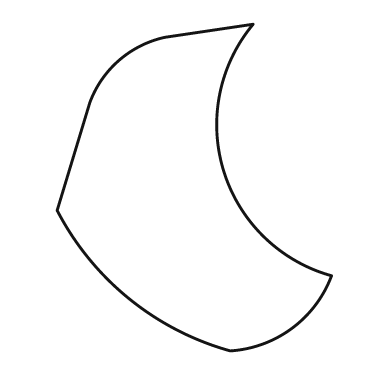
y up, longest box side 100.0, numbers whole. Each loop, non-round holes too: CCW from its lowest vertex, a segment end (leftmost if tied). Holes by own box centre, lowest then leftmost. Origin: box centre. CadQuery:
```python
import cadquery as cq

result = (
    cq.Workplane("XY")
    .moveTo(11.0, -50.0)
    .threePointArc((30.0, -43.0), (42.0, -27.0))
    .threePointArc((9.0, 5.0), (18.0, 50.0))
    .lineTo(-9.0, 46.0)
    .threePointArc((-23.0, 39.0), (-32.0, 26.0))
    .lineTo(-42.0, -7.0)
    .threePointArc((-20.0, -34.0), (11.0, -50.0))
    .close()
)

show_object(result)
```